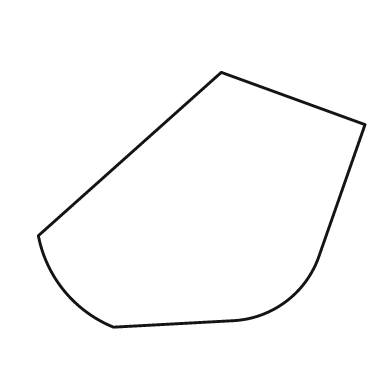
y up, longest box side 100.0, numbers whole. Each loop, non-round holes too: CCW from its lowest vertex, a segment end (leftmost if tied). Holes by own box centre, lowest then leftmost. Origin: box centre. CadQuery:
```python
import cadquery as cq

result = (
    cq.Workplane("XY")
    .moveTo(-27.0, -39.0)
    .lineTo(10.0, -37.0)
    .threePointArc((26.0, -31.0), (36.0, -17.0))
    .lineTo(50.0, 23.0)
    .lineTo(6.0, 39.0)
    .lineTo(-50.0, -11.0)
    .threePointArc((-42.0, -28.0), (-27.0, -39.0))
    .close()
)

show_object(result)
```